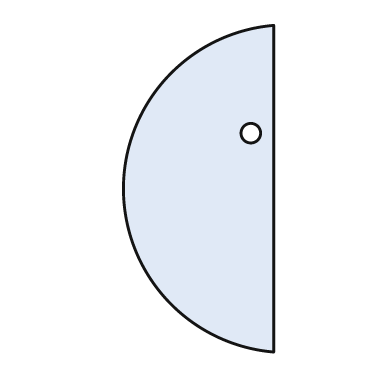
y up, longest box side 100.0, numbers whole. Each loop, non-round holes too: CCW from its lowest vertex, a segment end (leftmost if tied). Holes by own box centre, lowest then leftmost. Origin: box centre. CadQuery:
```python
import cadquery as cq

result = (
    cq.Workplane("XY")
    .moveTo(23.0, -50.0)
    .lineTo(23.0, 50.0)
    .threePointArc((-23.0, 0.0), (23.0, -50.0))
    .close()
    .moveTo(16.0, 17.0)
    .circle(3.0)
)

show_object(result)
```